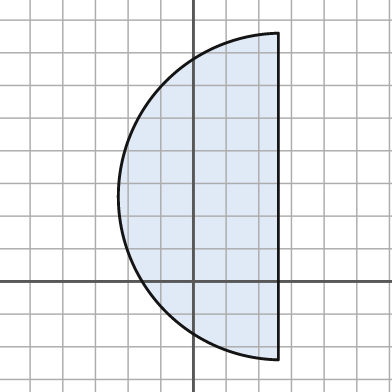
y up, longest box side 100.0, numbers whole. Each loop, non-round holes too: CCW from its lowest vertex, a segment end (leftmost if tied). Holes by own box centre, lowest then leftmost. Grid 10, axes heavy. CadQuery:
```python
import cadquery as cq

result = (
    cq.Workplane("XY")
    .moveTo(26.0, -24.0)
    .lineTo(26.0, 76.0)
    .threePointArc((-23.0, 26.0), (26.0, -24.0))
    .close()
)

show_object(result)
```